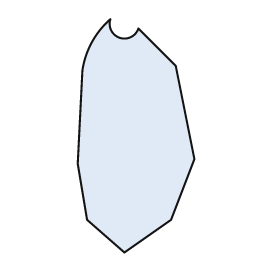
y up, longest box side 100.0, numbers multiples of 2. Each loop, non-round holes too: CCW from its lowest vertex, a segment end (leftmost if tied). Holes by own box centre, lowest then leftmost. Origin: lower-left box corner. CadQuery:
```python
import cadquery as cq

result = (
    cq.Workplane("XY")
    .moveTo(20.0, 0.0)
    .lineTo(40.0, 14.0)
    .lineTo(50.0, 40.0)
    .lineTo(42.0, 80.0)
    .lineTo(26.0, 96.0)
    .threePointArc((18.0, 92.0), (14.0, 100.0))
    .threePointArc((6.0, 90.0), (2.0, 78.0))
    .lineTo(0.0, 38.0)
    .lineTo(4.0, 14.0)
    .close()
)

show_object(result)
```